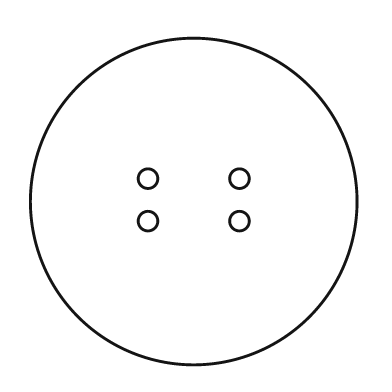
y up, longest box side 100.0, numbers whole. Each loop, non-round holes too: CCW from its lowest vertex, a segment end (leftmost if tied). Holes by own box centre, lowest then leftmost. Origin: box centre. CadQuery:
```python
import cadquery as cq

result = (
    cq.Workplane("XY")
    .moveTo(0.0, 0.0)
    .circle(50.0)
    .moveTo(-14.0, -6.0)
    .circle(3.0)
    .moveTo(14.0, -6.0)
    .circle(3.0)
    .moveTo(-14.0, 7.0)
    .circle(3.0)
    .moveTo(14.0, 7.0)
    .circle(3.0)
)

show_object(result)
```